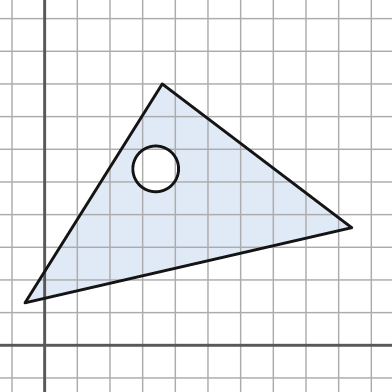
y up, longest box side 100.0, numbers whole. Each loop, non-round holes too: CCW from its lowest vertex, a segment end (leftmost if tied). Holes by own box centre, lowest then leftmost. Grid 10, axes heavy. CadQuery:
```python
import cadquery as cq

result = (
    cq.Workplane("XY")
    .moveTo(-6.0, 13.0)
    .lineTo(94.0, 36.0)
    .lineTo(36.0, 80.0)
    .close()
    .moveTo(34.0, 54.0)
    .circle(7.0)
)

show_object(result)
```